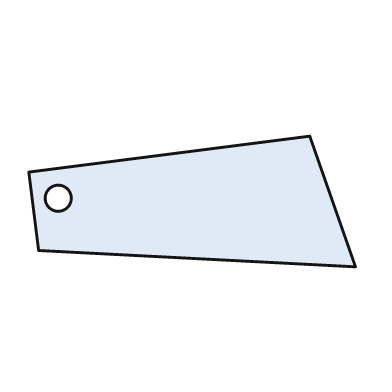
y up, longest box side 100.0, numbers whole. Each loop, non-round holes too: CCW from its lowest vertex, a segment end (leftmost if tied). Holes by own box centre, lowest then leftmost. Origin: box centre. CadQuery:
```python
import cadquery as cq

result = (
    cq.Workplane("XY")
    .moveTo(50.0, -20.0)
    .lineTo(36.0, 20.0)
    .lineTo(-50.0, 9.0)
    .lineTo(-47.0, -15.0)
    .close()
    .moveTo(-41.0, 1.0)
    .circle(4.0)
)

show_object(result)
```